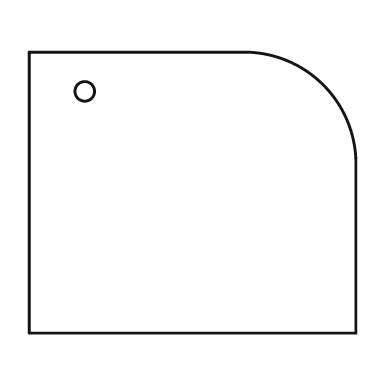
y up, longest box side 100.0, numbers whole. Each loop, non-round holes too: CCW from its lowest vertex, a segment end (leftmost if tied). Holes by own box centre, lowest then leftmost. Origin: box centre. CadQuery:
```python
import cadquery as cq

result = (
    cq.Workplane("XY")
    .moveTo(-50.0, -43.0)
    .lineTo(50.0, -43.0)
    .lineTo(50.0, 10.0)
    .threePointArc((40.0, 33.0), (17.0, 43.0))
    .lineTo(-50.0, 43.0)
    .close()
    .moveTo(-33.0, 31.0)
    .circle(3.0)
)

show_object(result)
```